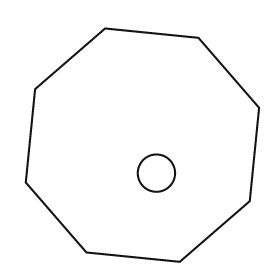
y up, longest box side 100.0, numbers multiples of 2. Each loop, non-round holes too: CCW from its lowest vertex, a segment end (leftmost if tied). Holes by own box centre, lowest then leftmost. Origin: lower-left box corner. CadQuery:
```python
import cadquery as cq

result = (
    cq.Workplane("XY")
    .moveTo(66.0, 0.0)
    .lineTo(96.0, 26.0)
    .lineTo(100.0, 66.0)
    .lineTo(74.0, 96.0)
    .lineTo(34.0, 100.0)
    .lineTo(4.0, 74.0)
    .lineTo(0.0, 34.0)
    .lineTo(26.0, 4.0)
    .close()
    .moveTo(56.0, 38.0)
    .circle(8.0)
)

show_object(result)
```